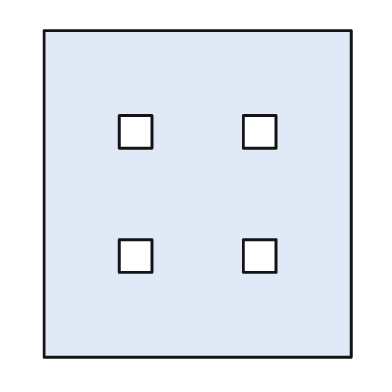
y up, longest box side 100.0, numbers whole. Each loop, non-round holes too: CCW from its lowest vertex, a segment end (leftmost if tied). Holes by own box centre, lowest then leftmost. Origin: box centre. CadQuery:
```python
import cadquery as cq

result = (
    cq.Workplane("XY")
    .moveTo(-47.0, -50.0)
    .lineTo(47.0, -50.0)
    .lineTo(47.0, 50.0)
    .lineTo(-47.0, 50.0)
    .close()
    .moveTo(-24.0, -24.0)
    .lineTo(-14.0, -24.0)
    .lineTo(-14.0, -14.0)
    .lineTo(-24.0, -14.0)
    .close()
    .moveTo(14.0, -24.0)
    .lineTo(24.0, -24.0)
    .lineTo(24.0, -14.0)
    .lineTo(14.0, -14.0)
    .close()
    .moveTo(-24.0, 14.0)
    .lineTo(-14.0, 14.0)
    .lineTo(-14.0, 24.0)
    .lineTo(-24.0, 24.0)
    .close()
    .moveTo(14.0, 14.0)
    .lineTo(24.0, 14.0)
    .lineTo(24.0, 24.0)
    .lineTo(14.0, 24.0)
    .close()
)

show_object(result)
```